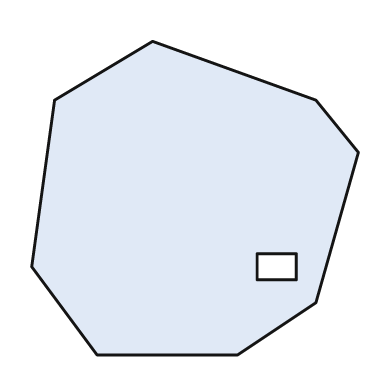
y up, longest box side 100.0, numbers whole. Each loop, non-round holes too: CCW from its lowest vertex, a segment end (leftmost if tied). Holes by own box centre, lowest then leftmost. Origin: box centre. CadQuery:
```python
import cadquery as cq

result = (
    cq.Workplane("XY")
    .moveTo(-30.0, -48.0)
    .lineTo(13.0, -48.0)
    .lineTo(37.0, -32.0)
    .lineTo(50.0, 14.0)
    .lineTo(37.0, 30.0)
    .lineTo(-13.0, 48.0)
    .lineTo(-43.0, 30.0)
    .lineTo(-50.0, -21.0)
    .close()
    .moveTo(19.0, -25.0)
    .lineTo(31.0, -25.0)
    .lineTo(31.0, -17.0)
    .lineTo(19.0, -17.0)
    .close()
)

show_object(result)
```